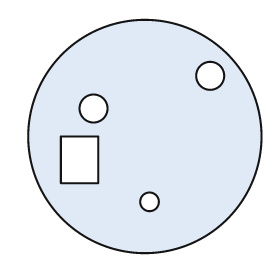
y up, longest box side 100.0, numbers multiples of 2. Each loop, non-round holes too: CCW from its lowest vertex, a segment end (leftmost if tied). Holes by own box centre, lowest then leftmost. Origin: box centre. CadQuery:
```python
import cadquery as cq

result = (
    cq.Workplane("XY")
    .moveTo(0.0, 0.0)
    .circle(50.0)
    .moveTo(2.0, -28.0)
    .circle(4.0)
    .moveTo(-36.0, -20.0)
    .lineTo(-20.0, -20.0)
    .lineTo(-20.0, 0.0)
    .lineTo(-36.0, 0.0)
    .close()
    .moveTo(-22.0, 12.0)
    .circle(6.0)
    .moveTo(28.0, 26.0)
    .circle(6.0)
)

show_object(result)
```